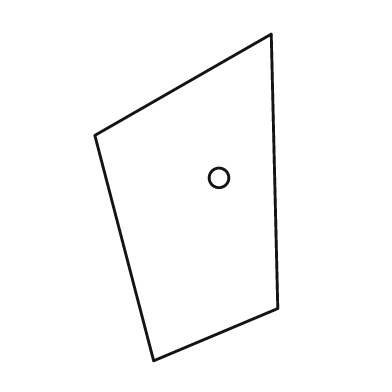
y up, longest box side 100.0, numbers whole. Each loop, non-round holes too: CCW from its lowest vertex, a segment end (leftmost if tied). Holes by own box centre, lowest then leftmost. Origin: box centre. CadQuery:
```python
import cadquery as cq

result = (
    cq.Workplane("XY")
    .moveTo(-10.0, -50.0)
    .lineTo(28.0, -34.0)
    .lineTo(26.0, 50.0)
    .lineTo(-28.0, 19.0)
    .close()
    .moveTo(10.0, 6.0)
    .circle(3.0)
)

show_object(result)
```